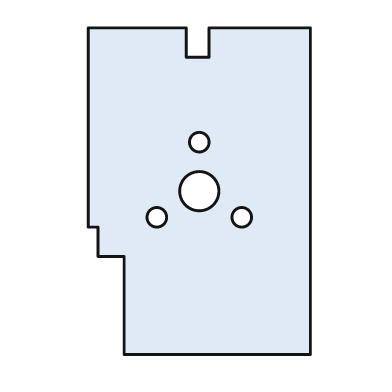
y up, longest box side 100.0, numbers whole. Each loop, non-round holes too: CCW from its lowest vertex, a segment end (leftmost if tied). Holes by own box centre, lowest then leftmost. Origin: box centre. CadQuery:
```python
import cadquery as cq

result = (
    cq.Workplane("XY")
    .moveTo(-23.0, -50.0)
    .lineTo(34.0, -50.0)
    .lineTo(34.0, 50.0)
    .lineTo(3.0, 50.0)
    .lineTo(3.0, 41.0)
    .lineTo(-4.0, 41.0)
    .lineTo(-4.0, 50.0)
    .lineTo(-34.0, 50.0)
    .lineTo(-34.0, -11.0)
    .lineTo(-31.0, -11.0)
    .lineTo(-31.0, -20.0)
    .lineTo(-23.0, -20.0)
    .close()
    .moveTo(-13.0, -8.0)
    .circle(3.0)
    .moveTo(13.0, -8.0)
    .circle(3.0)
    .moveTo(0.0, 0.0)
    .circle(6.0)
    .moveTo(0.0, 15.0)
    .circle(3.0)
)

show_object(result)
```